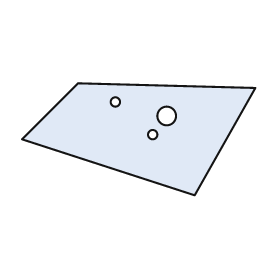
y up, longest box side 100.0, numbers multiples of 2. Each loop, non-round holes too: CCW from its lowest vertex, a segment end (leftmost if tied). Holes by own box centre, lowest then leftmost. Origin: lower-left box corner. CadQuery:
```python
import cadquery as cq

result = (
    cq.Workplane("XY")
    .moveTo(74.0, 0.0)
    .lineTo(100.0, 46.0)
    .lineTo(24.0, 48.0)
    .lineTo(0.0, 24.0)
    .close()
    .moveTo(56.0, 26.0)
    .circle(2.0)
    .moveTo(62.0, 34.0)
    .circle(4.0)
    .moveTo(40.0, 40.0)
    .circle(2.0)
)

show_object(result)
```